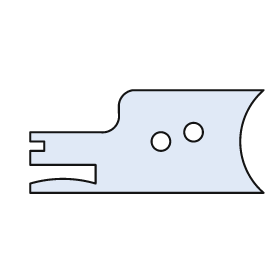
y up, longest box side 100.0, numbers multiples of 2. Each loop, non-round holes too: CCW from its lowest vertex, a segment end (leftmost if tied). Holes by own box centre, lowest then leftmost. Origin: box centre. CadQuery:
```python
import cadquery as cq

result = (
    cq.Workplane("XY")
    .moveTo(-50.0, -22.0)
    .lineTo(50.0, -22.0)
    .threePointArc((40.0, 0.0), (50.0, 22.0))
    .lineTo(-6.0, 22.0)
    .threePointArc((-10.0, 20.0), (-12.0, 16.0))
    .lineTo(-12.0, 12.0)
    .threePointArc((-14.0, 6.0), (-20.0, 4.0))
    .lineTo(-50.0, 4.0)
    .lineTo(-50.0, 0.0)
    .lineTo(-44.0, 0.0)
    .lineTo(-44.0, -4.0)
    .lineTo(-50.0, -4.0)
    .lineTo(-50.0, -10.0)
    .lineTo(-22.0, -10.0)
    .lineTo(-22.0, -18.0)
    .threePointArc((-36.0, -16.0), (-50.0, -18.0))
    .close()
    .moveTo(6.0, 0.0)
    .circle(4.0)
    .moveTo(20.0, 4.0)
    .circle(4.0)
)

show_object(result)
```